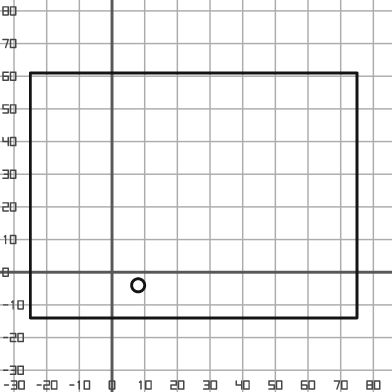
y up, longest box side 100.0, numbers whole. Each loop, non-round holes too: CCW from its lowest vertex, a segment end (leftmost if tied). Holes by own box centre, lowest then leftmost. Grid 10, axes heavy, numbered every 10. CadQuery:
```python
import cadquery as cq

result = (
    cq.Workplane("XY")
    .moveTo(-25.0, -14.0)
    .lineTo(75.0, -14.0)
    .lineTo(75.0, 61.0)
    .lineTo(-25.0, 61.0)
    .close()
    .moveTo(8.0, -4.0)
    .circle(2.0)
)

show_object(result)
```